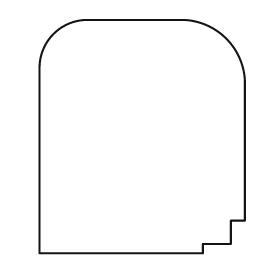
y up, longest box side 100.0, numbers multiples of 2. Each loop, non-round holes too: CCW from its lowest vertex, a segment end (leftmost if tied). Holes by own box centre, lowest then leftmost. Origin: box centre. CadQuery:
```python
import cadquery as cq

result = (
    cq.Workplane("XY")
    .moveTo(-44.0, -50.0)
    .lineTo(26.0, -50.0)
    .lineTo(26.0, -46.0)
    .lineTo(38.0, -46.0)
    .lineTo(38.0, -36.0)
    .lineTo(44.0, -36.0)
    .lineTo(44.0, 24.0)
    .threePointArc((36.0, 42.0), (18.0, 50.0))
    .lineTo(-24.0, 50.0)
    .threePointArc((-38.0, 44.0), (-44.0, 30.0))
    .close()
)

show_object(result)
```